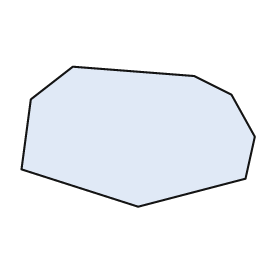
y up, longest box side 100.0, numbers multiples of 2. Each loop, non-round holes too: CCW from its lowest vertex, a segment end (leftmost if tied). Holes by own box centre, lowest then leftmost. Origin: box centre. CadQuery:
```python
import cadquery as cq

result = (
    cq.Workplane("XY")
    .moveTo(0.0, -30.0)
    .lineTo(46.0, -18.0)
    .lineTo(50.0, 0.0)
    .lineTo(40.0, 18.0)
    .lineTo(24.0, 26.0)
    .lineTo(-28.0, 30.0)
    .lineTo(-46.0, 16.0)
    .lineTo(-50.0, -14.0)
    .close()
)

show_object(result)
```